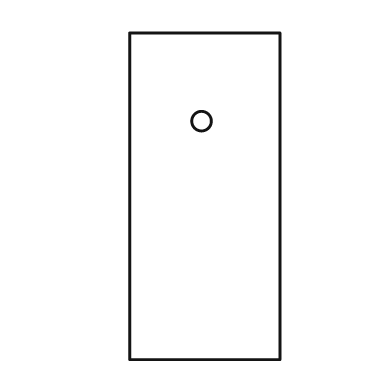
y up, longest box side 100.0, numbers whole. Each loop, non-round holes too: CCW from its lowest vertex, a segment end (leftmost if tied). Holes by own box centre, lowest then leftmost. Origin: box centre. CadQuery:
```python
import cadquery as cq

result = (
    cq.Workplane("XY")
    .moveTo(-23.0, -50.0)
    .lineTo(23.0, -50.0)
    .lineTo(23.0, 50.0)
    .lineTo(-23.0, 50.0)
    .close()
    .moveTo(-1.0, 23.0)
    .circle(3.0)
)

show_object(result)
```